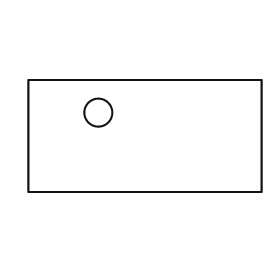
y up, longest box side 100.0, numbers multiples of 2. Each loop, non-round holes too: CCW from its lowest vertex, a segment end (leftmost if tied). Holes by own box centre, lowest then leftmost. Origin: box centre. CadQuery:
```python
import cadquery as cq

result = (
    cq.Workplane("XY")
    .moveTo(-50.0, -24.0)
    .lineTo(50.0, -24.0)
    .lineTo(50.0, 24.0)
    .lineTo(-50.0, 24.0)
    .close()
    .moveTo(-20.0, 10.0)
    .circle(6.0)
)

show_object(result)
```